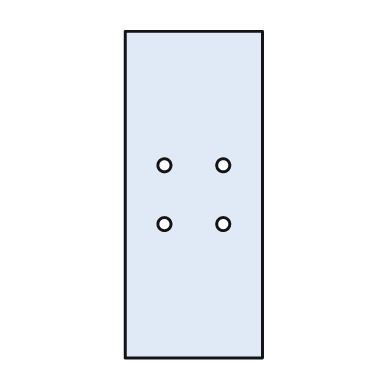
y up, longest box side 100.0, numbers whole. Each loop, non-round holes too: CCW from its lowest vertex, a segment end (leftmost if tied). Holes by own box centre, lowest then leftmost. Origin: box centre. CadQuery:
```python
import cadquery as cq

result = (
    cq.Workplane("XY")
    .moveTo(-21.0, -50.0)
    .lineTo(21.0, -50.0)
    .lineTo(21.0, 50.0)
    .lineTo(-21.0, 50.0)
    .close()
    .moveTo(-9.0, -9.0)
    .circle(2.0)
    .moveTo(9.0, -9.0)
    .circle(2.0)
    .moveTo(-9.0, 9.0)
    .circle(2.0)
    .moveTo(9.0, 9.0)
    .circle(2.0)
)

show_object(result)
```